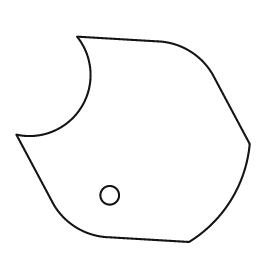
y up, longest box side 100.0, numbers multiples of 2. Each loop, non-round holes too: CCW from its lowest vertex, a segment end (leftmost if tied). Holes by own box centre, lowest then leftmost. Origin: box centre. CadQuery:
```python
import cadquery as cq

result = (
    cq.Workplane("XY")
    .moveTo(24.0, -44.0)
    .threePointArc((42.0, -26.0), (50.0, -2.0))
    .lineTo(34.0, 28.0)
    .threePointArc((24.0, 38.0), (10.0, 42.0))
    .lineTo(-24.0, 44.0)
    .threePointArc((-22.0, 14.0), (-50.0, 2.0))
    .lineTo(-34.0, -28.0)
    .threePointArc((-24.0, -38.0), (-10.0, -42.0))
    .close()
    .moveTo(-10.0, -24.0)
    .circle(4.0)
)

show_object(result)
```